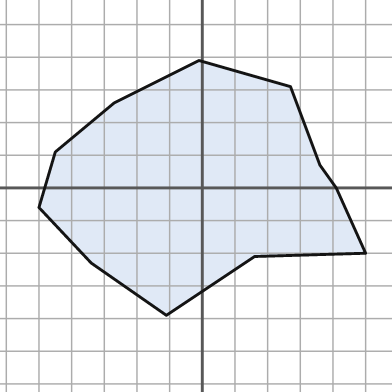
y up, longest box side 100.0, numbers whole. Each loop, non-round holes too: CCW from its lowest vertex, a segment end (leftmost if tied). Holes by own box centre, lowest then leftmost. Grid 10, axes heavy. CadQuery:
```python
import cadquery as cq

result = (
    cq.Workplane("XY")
    .moveTo(-11.0, -39.0)
    .lineTo(16.0, -21.0)
    .lineTo(50.0, -20.0)
    .lineTo(41.0, 0.0)
    .lineTo(36.0, 7.0)
    .lineTo(27.0, 31.0)
    .lineTo(-1.0, 39.0)
    .lineTo(-27.0, 26.0)
    .lineTo(-45.0, 11.0)
    .lineTo(-50.0, -6.0)
    .lineTo(-34.0, -23.0)
    .close()
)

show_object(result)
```